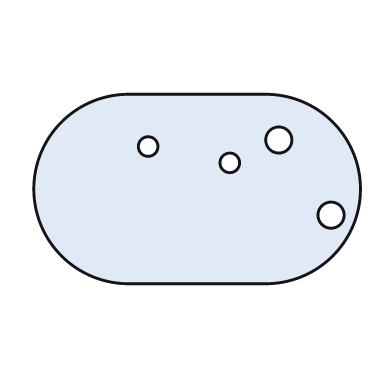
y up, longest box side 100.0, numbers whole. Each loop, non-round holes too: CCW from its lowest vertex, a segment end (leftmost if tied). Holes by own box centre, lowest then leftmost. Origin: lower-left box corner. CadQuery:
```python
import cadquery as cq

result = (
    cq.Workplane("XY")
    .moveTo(29.0, 0.0)
    .lineTo(71.0, 0.0)
    .threePointArc((100.0, 29.0), (71.0, 58.0))
    .lineTo(29.0, 58.0)
    .threePointArc((0.0, 29.0), (29.0, 0.0))
    .close()
    .moveTo(91.0, 21.0)
    .circle(4.0)
    .moveTo(60.0, 37.0)
    .circle(3.0)
    .moveTo(35.0, 42.0)
    .circle(3.0)
    .moveTo(75.0, 44.0)
    .circle(4.0)
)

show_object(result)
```